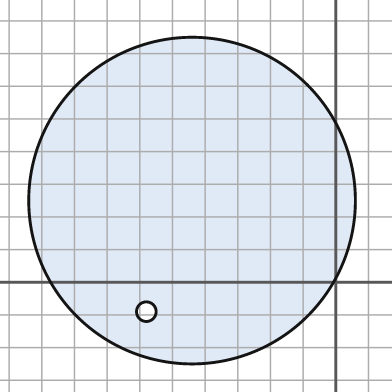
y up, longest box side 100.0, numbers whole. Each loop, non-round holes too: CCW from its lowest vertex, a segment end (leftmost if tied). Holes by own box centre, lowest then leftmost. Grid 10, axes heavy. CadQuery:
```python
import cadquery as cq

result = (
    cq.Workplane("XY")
    .moveTo(-44.0, 25.0)
    .circle(50.0)
    .moveTo(-58.0, -9.0)
    .circle(3.0)
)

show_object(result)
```